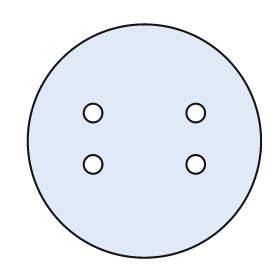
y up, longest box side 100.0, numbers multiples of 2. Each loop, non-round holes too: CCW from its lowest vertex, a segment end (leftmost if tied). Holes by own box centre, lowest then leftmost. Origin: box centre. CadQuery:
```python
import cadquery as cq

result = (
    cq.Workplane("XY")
    .moveTo(0.0, 0.0)
    .circle(50.0)
    .moveTo(-22.0, -10.0)
    .circle(4.0)
    .moveTo(22.0, -10.0)
    .circle(4.0)
    .moveTo(-22.0, 12.0)
    .circle(4.0)
    .moveTo(22.0, 12.0)
    .circle(4.0)
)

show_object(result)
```